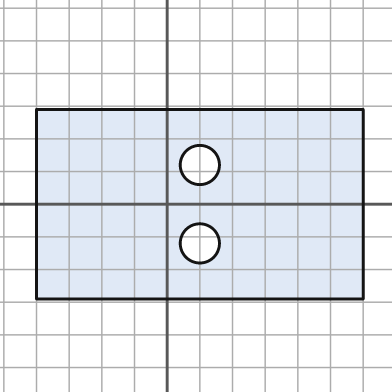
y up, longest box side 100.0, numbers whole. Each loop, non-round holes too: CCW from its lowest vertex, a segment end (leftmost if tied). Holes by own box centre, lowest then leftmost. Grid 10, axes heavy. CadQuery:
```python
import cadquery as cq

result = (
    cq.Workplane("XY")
    .moveTo(-40.0, -29.0)
    .lineTo(60.0, -29.0)
    .lineTo(60.0, 29.0)
    .lineTo(-40.0, 29.0)
    .close()
    .moveTo(10.0, -12.0)
    .circle(6.0)
    .moveTo(10.0, 12.0)
    .circle(6.0)
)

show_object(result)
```